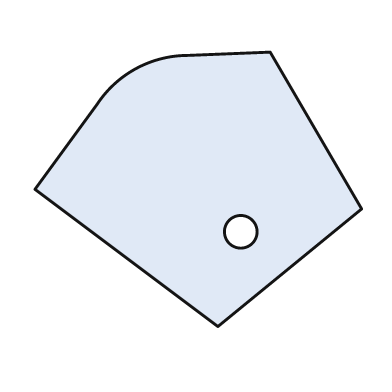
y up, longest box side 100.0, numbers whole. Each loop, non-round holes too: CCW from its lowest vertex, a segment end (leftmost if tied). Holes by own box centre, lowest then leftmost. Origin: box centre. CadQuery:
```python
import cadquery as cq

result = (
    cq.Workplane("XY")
    .moveTo(6.0, -42.0)
    .lineTo(50.0, -6.0)
    .lineTo(22.0, 42.0)
    .lineTo(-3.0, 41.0)
    .threePointArc((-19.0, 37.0), (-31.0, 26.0))
    .lineTo(-50.0, 0.0)
    .close()
    .moveTo(13.0, -13.0)
    .circle(5.0)
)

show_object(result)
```